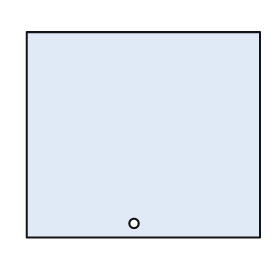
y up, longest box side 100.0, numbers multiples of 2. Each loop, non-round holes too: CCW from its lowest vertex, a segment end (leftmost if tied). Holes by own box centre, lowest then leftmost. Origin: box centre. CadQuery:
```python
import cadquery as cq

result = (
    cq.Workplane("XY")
    .moveTo(-50.0, -44.0)
    .lineTo(50.0, -44.0)
    .lineTo(50.0, 44.0)
    .lineTo(-50.0, 44.0)
    .close()
    .moveTo(-4.0, -38.0)
    .circle(2.0)
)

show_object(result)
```